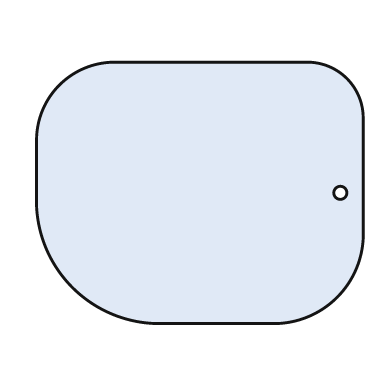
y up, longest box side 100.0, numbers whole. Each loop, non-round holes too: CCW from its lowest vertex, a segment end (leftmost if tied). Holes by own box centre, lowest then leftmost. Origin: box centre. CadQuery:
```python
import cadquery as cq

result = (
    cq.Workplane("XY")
    .moveTo(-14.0, -40.0)
    .lineTo(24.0, -40.0)
    .threePointArc((42.0, -32.0), (50.0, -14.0))
    .lineTo(50.0, 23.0)
    .threePointArc((45.0, 35.0), (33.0, 40.0))
    .lineTo(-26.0, 40.0)
    .threePointArc((-43.0, 33.0), (-50.0, 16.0))
    .lineTo(-50.0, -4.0)
    .threePointArc((-39.0, -29.0), (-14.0, -40.0))
    .close()
    .moveTo(43.0, 0.0)
    .circle(2.0)
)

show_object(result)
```